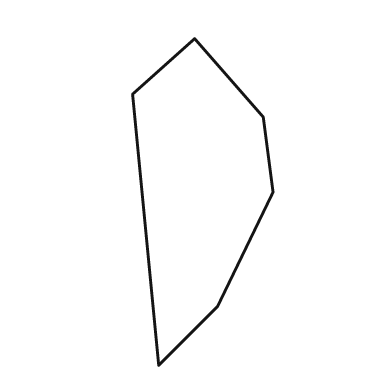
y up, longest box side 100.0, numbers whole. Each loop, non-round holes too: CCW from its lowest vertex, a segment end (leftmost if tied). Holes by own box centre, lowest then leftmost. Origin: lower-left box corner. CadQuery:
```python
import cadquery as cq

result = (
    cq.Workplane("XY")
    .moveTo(8.0, 0.0)
    .lineTo(26.0, 18.0)
    .lineTo(43.0, 53.0)
    .lineTo(40.0, 76.0)
    .lineTo(19.0, 100.0)
    .lineTo(0.0, 83.0)
    .close()
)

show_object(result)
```